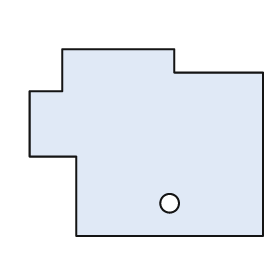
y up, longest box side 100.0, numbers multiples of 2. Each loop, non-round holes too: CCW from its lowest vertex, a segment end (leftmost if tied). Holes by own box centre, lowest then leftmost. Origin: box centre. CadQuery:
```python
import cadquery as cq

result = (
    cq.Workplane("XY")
    .moveTo(-30.0, -40.0)
    .lineTo(50.0, -40.0)
    .lineTo(50.0, 30.0)
    .lineTo(12.0, 30.0)
    .lineTo(12.0, 40.0)
    .lineTo(-36.0, 40.0)
    .lineTo(-36.0, 22.0)
    .lineTo(-50.0, 22.0)
    .lineTo(-50.0, -6.0)
    .lineTo(-30.0, -6.0)
    .close()
    .moveTo(10.0, -26.0)
    .circle(4.0)
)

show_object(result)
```